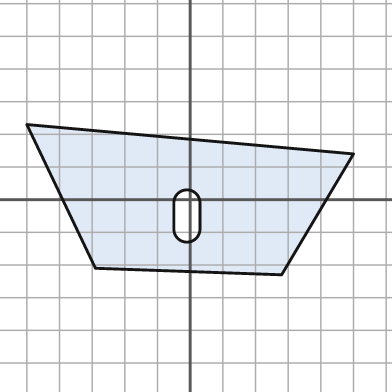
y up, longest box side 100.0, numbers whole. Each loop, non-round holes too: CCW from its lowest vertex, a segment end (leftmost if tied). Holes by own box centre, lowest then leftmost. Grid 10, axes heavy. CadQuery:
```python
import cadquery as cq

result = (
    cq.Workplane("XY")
    .moveTo(28.0, -23.0)
    .lineTo(50.0, 14.0)
    .lineTo(-50.0, 23.0)
    .lineTo(-29.0, -21.0)
    .close()
    .moveTo(-5.0, -9.0)
    .threePointArc((-1.0, -13.0), (3.0, -9.0))
    .lineTo(3.0, -1.0)
    .threePointArc((-1.0, 3.0), (-5.0, -1.0))
    .close()
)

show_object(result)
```